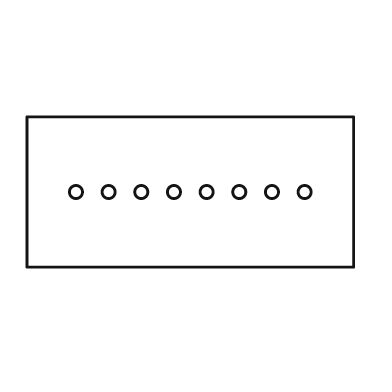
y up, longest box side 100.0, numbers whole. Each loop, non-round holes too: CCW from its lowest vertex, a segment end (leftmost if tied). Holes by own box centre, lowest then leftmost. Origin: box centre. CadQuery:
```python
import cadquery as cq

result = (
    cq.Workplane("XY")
    .moveTo(-50.0, -23.0)
    .lineTo(50.0, -23.0)
    .lineTo(50.0, 23.0)
    .lineTo(-50.0, 23.0)
    .close()
    .moveTo(-35.0, 0.0)
    .circle(2.0)
    .moveTo(-25.0, 0.0)
    .circle(2.0)
    .moveTo(-15.0, 0.0)
    .circle(2.0)
    .moveTo(-5.0, 0.0)
    .circle(2.0)
    .moveTo(5.0, 0.0)
    .circle(2.0)
    .moveTo(15.0, 0.0)
    .circle(2.0)
    .moveTo(25.0, 0.0)
    .circle(2.0)
    .moveTo(35.0, 0.0)
    .circle(2.0)
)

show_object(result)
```